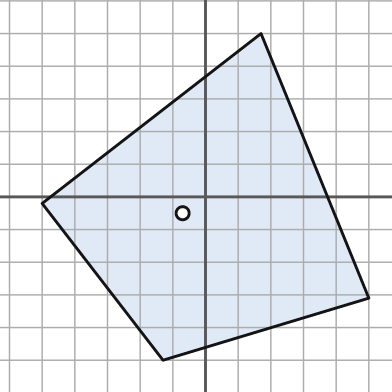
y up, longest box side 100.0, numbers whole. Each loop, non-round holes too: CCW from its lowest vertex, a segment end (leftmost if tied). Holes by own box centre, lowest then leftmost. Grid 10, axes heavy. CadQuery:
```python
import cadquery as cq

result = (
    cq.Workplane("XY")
    .moveTo(-13.0, -50.0)
    .lineTo(50.0, -31.0)
    .lineTo(17.0, 50.0)
    .lineTo(-50.0, -2.0)
    .close()
    .moveTo(-7.0, -5.0)
    .circle(2.0)
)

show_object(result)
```